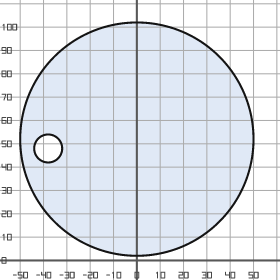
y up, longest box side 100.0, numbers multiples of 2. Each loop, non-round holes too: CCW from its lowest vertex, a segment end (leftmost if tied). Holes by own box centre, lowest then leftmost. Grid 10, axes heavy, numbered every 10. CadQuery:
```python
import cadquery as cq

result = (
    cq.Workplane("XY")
    .moveTo(0.0, 52.0)
    .circle(50.0)
    .moveTo(-38.0, 48.0)
    .circle(6.0)
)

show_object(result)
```